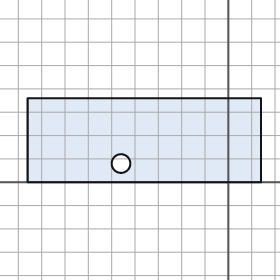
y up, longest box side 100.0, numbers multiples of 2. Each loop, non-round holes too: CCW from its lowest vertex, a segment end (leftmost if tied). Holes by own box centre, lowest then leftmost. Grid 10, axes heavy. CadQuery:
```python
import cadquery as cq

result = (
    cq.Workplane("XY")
    .moveTo(-86.0, 0.0)
    .lineTo(14.0, 0.0)
    .lineTo(14.0, 36.0)
    .lineTo(-86.0, 36.0)
    .close()
    .moveTo(-46.0, 8.0)
    .circle(4.0)
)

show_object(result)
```